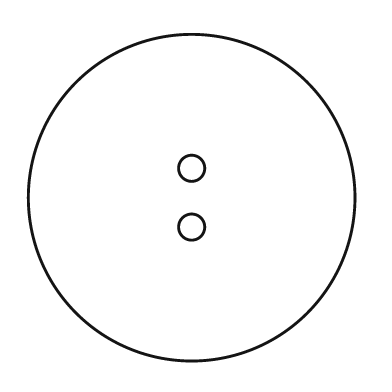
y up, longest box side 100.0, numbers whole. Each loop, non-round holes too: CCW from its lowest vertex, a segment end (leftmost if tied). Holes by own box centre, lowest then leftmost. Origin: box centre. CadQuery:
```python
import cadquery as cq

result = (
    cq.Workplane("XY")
    .moveTo(0.0, 0.0)
    .circle(50.0)
    .moveTo(0.0, -9.0)
    .circle(4.0)
    .moveTo(0.0, 9.0)
    .circle(4.0)
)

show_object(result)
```